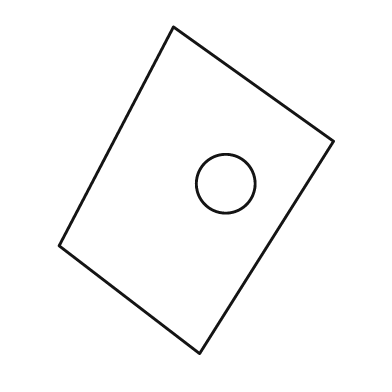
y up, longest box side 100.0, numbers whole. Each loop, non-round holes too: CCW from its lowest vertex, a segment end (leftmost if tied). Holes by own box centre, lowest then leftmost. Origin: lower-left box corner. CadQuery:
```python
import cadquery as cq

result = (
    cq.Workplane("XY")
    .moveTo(43.0, 0.0)
    .lineTo(84.0, 65.0)
    .lineTo(35.0, 100.0)
    .lineTo(0.0, 33.0)
    .close()
    .moveTo(51.0, 52.0)
    .circle(9.0)
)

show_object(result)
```